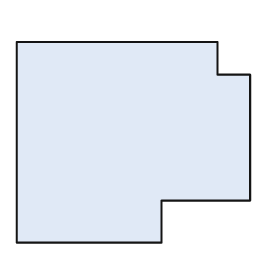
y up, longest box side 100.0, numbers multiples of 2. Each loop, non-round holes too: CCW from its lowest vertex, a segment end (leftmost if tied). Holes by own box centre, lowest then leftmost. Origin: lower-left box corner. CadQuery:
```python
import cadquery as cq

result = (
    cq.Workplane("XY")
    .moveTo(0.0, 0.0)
    .lineTo(62.0, 0.0)
    .lineTo(62.0, 18.0)
    .lineTo(100.0, 18.0)
    .lineTo(100.0, 72.0)
    .lineTo(86.0, 72.0)
    .lineTo(86.0, 86.0)
    .lineTo(0.0, 86.0)
    .close()
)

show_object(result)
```